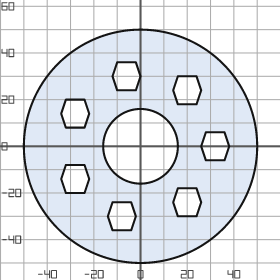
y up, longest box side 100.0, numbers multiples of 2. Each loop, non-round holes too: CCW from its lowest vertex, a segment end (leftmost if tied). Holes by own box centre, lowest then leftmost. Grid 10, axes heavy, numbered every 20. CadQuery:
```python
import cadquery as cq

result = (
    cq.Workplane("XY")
    .moveTo(0.0, 0.0)
    .circle(50.0)
    .moveTo(-12.0, -36.0)
    .lineTo(-4.0, -36.0)
    .lineTo(-2.0, -30.0)
    .lineTo(-4.0, -24.0)
    .lineTo(-12.0, -24.0)
    .lineTo(-14.0, -30.0)
    .close()
    .moveTo(16.0, -30.0)
    .lineTo(24.0, -30.0)
    .lineTo(26.0, -24.0)
    .lineTo(24.0, -18.0)
    .lineTo(16.0, -18.0)
    .lineTo(14.0, -24.0)
    .close()
    .moveTo(-32.0, -20.0)
    .lineTo(-24.0, -20.0)
    .lineTo(-22.0, -14.0)
    .lineTo(-24.0, -8.0)
    .lineTo(-32.0, -8.0)
    .lineTo(-34.0, -14.0)
    .close()
    .moveTo(0.0, 0.0)
    .circle(16.0)
    .moveTo(28.0, -6.0)
    .lineTo(36.0, -6.0)
    .lineTo(38.0, 0.0)
    .lineTo(36.0, 6.0)
    .lineTo(28.0, 6.0)
    .lineTo(26.0, 0.0)
    .close()
    .moveTo(-32.0, 8.0)
    .lineTo(-24.0, 8.0)
    .lineTo(-22.0, 14.0)
    .lineTo(-24.0, 20.0)
    .lineTo(-32.0, 20.0)
    .lineTo(-34.0, 14.0)
    .close()
    .moveTo(16.0, 18.0)
    .lineTo(24.0, 18.0)
    .lineTo(26.0, 24.0)
    .lineTo(24.0, 30.0)
    .lineTo(16.0, 30.0)
    .lineTo(14.0, 24.0)
    .close()
    .moveTo(-10.0, 24.0)
    .lineTo(-2.0, 24.0)
    .lineTo(0.0, 30.0)
    .lineTo(-2.0, 36.0)
    .lineTo(-10.0, 36.0)
    .lineTo(-12.0, 30.0)
    .close()
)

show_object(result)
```